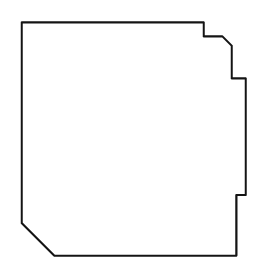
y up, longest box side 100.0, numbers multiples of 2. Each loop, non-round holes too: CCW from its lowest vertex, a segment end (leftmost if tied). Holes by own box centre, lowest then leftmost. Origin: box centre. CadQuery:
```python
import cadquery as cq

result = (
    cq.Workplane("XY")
    .moveTo(-34.0, -50.0)
    .lineTo(44.0, -50.0)
    .lineTo(44.0, -24.0)
    .lineTo(48.0, -24.0)
    .lineTo(48.0, 26.0)
    .lineTo(42.0, 26.0)
    .lineTo(42.0, 40.0)
    .lineTo(38.0, 44.0)
    .lineTo(30.0, 44.0)
    .lineTo(30.0, 50.0)
    .lineTo(-48.0, 50.0)
    .lineTo(-48.0, -36.0)
    .close()
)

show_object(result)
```